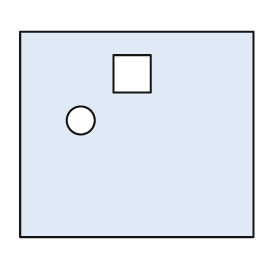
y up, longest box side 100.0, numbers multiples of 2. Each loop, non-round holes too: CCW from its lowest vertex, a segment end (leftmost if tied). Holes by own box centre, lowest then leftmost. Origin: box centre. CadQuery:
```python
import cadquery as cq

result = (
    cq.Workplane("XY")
    .moveTo(-50.0, -44.0)
    .lineTo(50.0, -44.0)
    .lineTo(50.0, 44.0)
    .lineTo(-50.0, 44.0)
    .close()
    .moveTo(-24.0, 6.0)
    .circle(6.0)
    .moveTo(-10.0, 18.0)
    .lineTo(6.0, 18.0)
    .lineTo(6.0, 34.0)
    .lineTo(-10.0, 34.0)
    .close()
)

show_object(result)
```